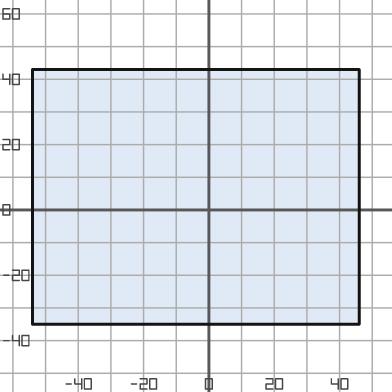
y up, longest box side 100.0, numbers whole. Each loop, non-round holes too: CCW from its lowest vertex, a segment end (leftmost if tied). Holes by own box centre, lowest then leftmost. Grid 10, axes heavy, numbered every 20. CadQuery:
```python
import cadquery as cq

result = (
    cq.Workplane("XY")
    .moveTo(-54.0, -35.0)
    .lineTo(46.0, -35.0)
    .lineTo(46.0, 43.0)
    .lineTo(-54.0, 43.0)
    .close()
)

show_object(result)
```